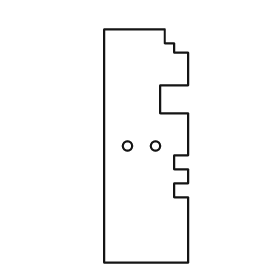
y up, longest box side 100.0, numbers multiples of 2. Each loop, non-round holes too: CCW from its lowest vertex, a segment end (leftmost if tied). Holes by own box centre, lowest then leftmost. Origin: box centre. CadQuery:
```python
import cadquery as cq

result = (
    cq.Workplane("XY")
    .moveTo(-18.0, -50.0)
    .lineTo(18.0, -50.0)
    .lineTo(18.0, -22.0)
    .lineTo(12.0, -22.0)
    .lineTo(12.0, -16.0)
    .lineTo(18.0, -16.0)
    .lineTo(18.0, -10.0)
    .lineTo(12.0, -10.0)
    .lineTo(12.0, -4.0)
    .lineTo(18.0, -4.0)
    .lineTo(18.0, 14.0)
    .lineTo(6.0, 14.0)
    .lineTo(6.0, 26.0)
    .lineTo(18.0, 26.0)
    .lineTo(18.0, 40.0)
    .lineTo(12.0, 40.0)
    .lineTo(12.0, 44.0)
    .lineTo(8.0, 44.0)
    .lineTo(8.0, 50.0)
    .lineTo(-18.0, 50.0)
    .close()
    .moveTo(-8.0, 0.0)
    .circle(2.0)
    .moveTo(4.0, 0.0)
    .circle(2.0)
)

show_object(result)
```